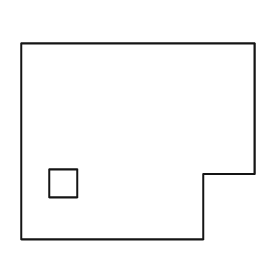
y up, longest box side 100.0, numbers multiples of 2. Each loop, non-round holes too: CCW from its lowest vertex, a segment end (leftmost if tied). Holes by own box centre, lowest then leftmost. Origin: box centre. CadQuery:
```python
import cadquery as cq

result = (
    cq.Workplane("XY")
    .moveTo(-50.0, -42.0)
    .lineTo(28.0, -42.0)
    .lineTo(28.0, -14.0)
    .lineTo(50.0, -14.0)
    .lineTo(50.0, 42.0)
    .lineTo(-50.0, 42.0)
    .close()
    .moveTo(-38.0, -24.0)
    .lineTo(-26.0, -24.0)
    .lineTo(-26.0, -12.0)
    .lineTo(-38.0, -12.0)
    .close()
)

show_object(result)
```